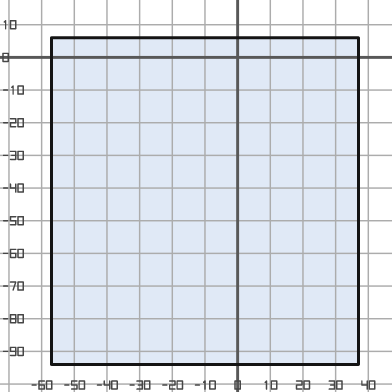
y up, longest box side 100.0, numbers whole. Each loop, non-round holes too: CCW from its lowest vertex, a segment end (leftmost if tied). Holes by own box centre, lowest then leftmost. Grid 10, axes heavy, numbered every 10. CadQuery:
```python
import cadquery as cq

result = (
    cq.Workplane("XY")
    .moveTo(-57.0, -94.0)
    .lineTo(37.0, -94.0)
    .lineTo(37.0, 6.0)
    .lineTo(-57.0, 6.0)
    .close()
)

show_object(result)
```